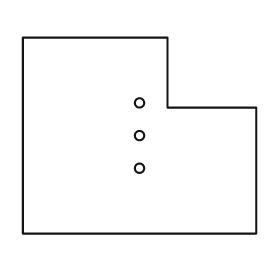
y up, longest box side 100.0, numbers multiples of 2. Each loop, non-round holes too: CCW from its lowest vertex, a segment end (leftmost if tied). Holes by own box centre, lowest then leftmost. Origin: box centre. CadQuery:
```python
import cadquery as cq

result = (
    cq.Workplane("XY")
    .moveTo(-50.0, -42.0)
    .lineTo(50.0, -42.0)
    .lineTo(50.0, 12.0)
    .lineTo(12.0, 12.0)
    .lineTo(12.0, 42.0)
    .lineTo(-50.0, 42.0)
    .close()
    .moveTo(0.0, -14.0)
    .circle(2.0)
    .moveTo(0.0, 0.0)
    .circle(2.0)
    .moveTo(0.0, 14.0)
    .circle(2.0)
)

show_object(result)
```